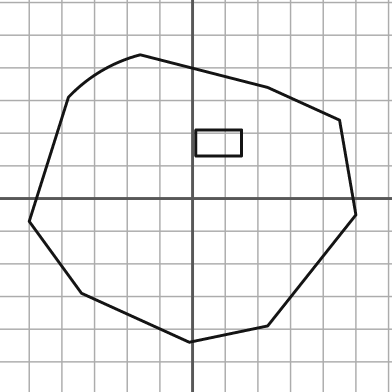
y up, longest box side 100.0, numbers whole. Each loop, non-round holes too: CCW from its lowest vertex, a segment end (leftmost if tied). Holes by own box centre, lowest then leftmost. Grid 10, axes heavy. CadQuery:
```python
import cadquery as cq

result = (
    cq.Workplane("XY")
    .moveTo(-1.0, -44.0)
    .lineTo(23.0, -39.0)
    .lineTo(50.0, -5.0)
    .lineTo(45.0, 24.0)
    .lineTo(23.0, 34.0)
    .lineTo(-16.0, 44.0)
    .threePointArc((-28.0, 39.0), (-38.0, 31.0))
    .lineTo(-50.0, -7.0)
    .lineTo(-34.0, -29.0)
    .close()
    .moveTo(1.0, 13.0)
    .lineTo(15.0, 13.0)
    .lineTo(15.0, 21.0)
    .lineTo(1.0, 21.0)
    .close()
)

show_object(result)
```